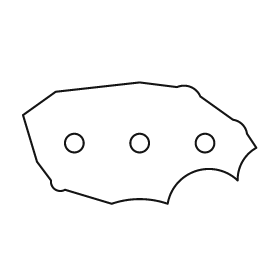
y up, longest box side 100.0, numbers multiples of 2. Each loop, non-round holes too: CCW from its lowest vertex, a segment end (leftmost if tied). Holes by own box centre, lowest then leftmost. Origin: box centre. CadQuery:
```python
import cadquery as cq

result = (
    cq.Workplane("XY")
    .moveTo(-12.0, -26.0)
    .threePointArc((0.0, -24.0), (12.0, -26.0))
    .threePointArc((24.0, -12.0), (42.0, -16.0))
    .threePointArc((44.0, -8.0), (50.0, -2.0))
    .lineTo(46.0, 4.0)
    .threePointArc((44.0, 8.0), (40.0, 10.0))
    .lineTo(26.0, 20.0)
    .threePointArc((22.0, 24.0), (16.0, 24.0))
    .lineTo(0.0, 26.0)
    .lineTo(-36.0, 22.0)
    .lineTo(-50.0, 12.0)
    .lineTo(-44.0, -8.0)
    .lineTo(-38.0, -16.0)
    .threePointArc((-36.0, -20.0), (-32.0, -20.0))
    .close()
    .moveTo(-28.0, 0.0)
    .circle(4.0)
    .moveTo(0.0, 0.0)
    .circle(4.0)
    .moveTo(28.0, 0.0)
    .circle(4.0)
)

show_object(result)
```